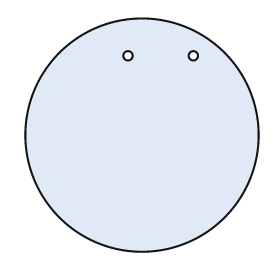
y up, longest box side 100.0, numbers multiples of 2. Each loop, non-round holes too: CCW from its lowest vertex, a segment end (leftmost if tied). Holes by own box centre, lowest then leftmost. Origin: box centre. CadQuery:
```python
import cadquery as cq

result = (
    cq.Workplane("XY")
    .moveTo(0.0, 0.0)
    .circle(50.0)
    .moveTo(-6.0, 34.0)
    .circle(2.0)
    .moveTo(22.0, 34.0)
    .circle(2.0)
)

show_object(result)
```